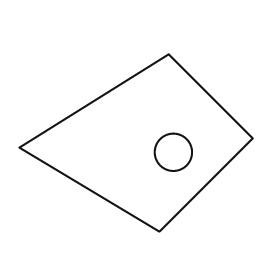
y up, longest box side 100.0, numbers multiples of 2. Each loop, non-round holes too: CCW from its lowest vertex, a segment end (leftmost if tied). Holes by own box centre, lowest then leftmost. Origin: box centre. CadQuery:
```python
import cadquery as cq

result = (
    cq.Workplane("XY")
    .moveTo(10.0, -38.0)
    .lineTo(50.0, 2.0)
    .lineTo(14.0, 38.0)
    .lineTo(-50.0, -2.0)
    .close()
    .moveTo(16.0, -4.0)
    .circle(8.0)
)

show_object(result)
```